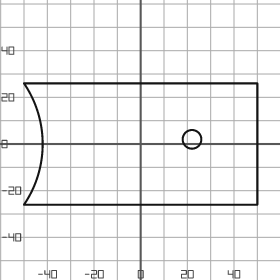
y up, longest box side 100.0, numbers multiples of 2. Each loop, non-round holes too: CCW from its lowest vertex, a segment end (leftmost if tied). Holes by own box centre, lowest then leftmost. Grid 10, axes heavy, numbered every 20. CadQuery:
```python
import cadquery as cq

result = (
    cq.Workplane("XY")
    .moveTo(-50.0, -26.0)
    .lineTo(50.0, -26.0)
    .lineTo(50.0, 26.0)
    .lineTo(-50.0, 26.0)
    .threePointArc((-42.0, 0.0), (-50.0, -26.0))
    .close()
    .moveTo(22.0, 2.0)
    .circle(4.0)
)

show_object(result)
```